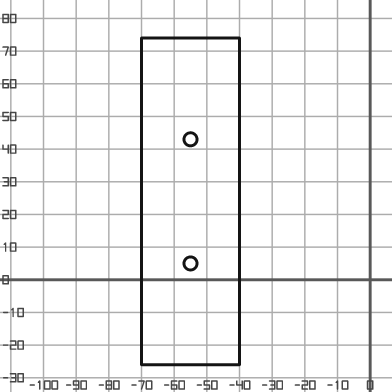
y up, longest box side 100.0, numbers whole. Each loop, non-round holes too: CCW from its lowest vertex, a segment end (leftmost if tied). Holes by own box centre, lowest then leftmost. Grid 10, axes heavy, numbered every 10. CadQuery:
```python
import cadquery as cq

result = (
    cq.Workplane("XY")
    .moveTo(-70.0, -26.0)
    .lineTo(-40.0, -26.0)
    .lineTo(-40.0, 74.0)
    .lineTo(-70.0, 74.0)
    .close()
    .moveTo(-55.0, 5.0)
    .circle(2.0)
    .moveTo(-55.0, 43.0)
    .circle(2.0)
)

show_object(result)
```